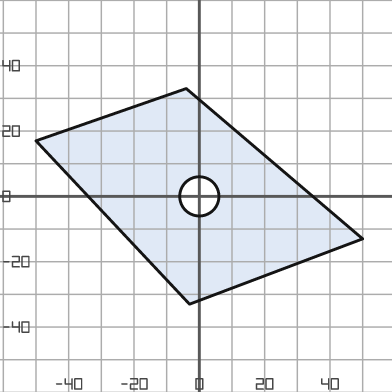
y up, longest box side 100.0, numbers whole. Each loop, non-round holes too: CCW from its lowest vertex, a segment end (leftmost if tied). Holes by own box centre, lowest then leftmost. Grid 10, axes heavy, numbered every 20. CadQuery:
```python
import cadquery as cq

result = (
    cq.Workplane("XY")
    .moveTo(-3.0, -33.0)
    .lineTo(50.0, -13.0)
    .lineTo(-4.0, 33.0)
    .lineTo(-50.0, 17.0)
    .close()
    .moveTo(0.0, 0.0)
    .circle(6.0)
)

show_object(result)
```